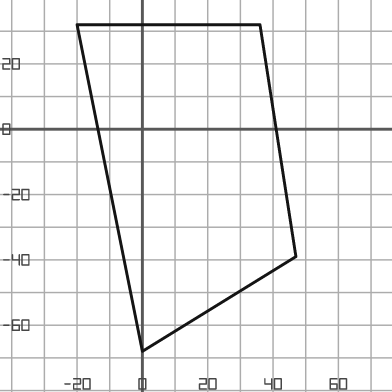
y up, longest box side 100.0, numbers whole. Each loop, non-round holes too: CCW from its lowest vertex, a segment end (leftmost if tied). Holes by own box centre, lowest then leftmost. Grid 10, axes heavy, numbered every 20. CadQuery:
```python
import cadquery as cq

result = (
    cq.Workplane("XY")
    .moveTo(0.0, -68.0)
    .lineTo(47.0, -39.0)
    .lineTo(36.0, 32.0)
    .lineTo(-20.0, 32.0)
    .close()
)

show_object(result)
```